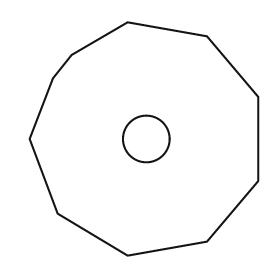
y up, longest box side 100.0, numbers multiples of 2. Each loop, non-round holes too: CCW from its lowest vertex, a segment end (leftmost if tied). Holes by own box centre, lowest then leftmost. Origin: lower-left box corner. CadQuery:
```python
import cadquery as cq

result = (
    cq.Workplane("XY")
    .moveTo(42.0, 0.0)
    .lineTo(76.0, 6.0)
    .lineTo(98.0, 32.0)
    .lineTo(98.0, 68.0)
    .lineTo(76.0, 94.0)
    .lineTo(42.0, 100.0)
    .lineTo(18.0, 86.0)
    .lineTo(10.0, 76.0)
    .lineTo(0.0, 50.0)
    .lineTo(12.0, 18.0)
    .close()
    .moveTo(50.0, 50.0)
    .circle(10.0)
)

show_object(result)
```